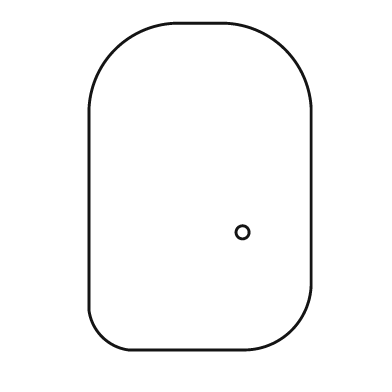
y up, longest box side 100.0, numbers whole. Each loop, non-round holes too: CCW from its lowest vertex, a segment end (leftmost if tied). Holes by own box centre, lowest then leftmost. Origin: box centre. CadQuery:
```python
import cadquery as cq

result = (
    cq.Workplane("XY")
    .moveTo(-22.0, -50.0)
    .lineTo(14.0, -50.0)
    .threePointArc((28.0, -44.0), (34.0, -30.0))
    .lineTo(34.0, 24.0)
    .threePointArc((26.0, 42.0), (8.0, 50.0))
    .lineTo(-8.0, 50.0)
    .threePointArc((-26.0, 42.0), (-34.0, 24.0))
    .lineTo(-34.0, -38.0)
    .threePointArc((-30.0, -46.0), (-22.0, -50.0))
    .close()
    .moveTo(13.0, -14.0)
    .circle(2.0)
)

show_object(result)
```